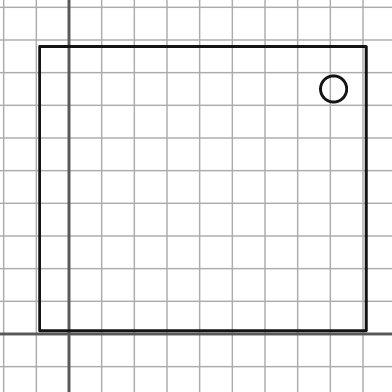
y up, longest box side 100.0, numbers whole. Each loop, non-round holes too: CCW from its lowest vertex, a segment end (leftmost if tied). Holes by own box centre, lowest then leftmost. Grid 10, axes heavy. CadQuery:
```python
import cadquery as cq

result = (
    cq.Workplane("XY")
    .moveTo(-9.0, 1.0)
    .lineTo(91.0, 1.0)
    .lineTo(91.0, 88.0)
    .lineTo(-9.0, 88.0)
    .close()
    .moveTo(81.0, 75.0)
    .circle(4.0)
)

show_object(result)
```